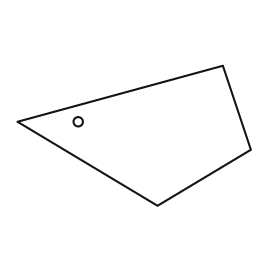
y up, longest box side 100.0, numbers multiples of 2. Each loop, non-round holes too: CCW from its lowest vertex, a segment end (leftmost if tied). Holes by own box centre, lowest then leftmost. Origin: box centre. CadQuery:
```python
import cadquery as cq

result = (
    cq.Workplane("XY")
    .moveTo(10.0, -30.0)
    .lineTo(50.0, -6.0)
    .lineTo(38.0, 30.0)
    .lineTo(-50.0, 6.0)
    .close()
    .moveTo(-24.0, 6.0)
    .circle(2.0)
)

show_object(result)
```